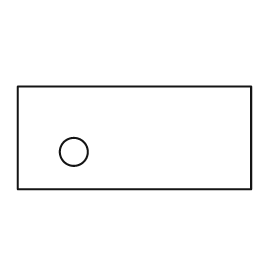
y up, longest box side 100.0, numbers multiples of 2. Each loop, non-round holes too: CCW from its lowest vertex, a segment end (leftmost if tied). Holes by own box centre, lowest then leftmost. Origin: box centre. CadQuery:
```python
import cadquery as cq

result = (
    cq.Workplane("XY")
    .moveTo(-50.0, -22.0)
    .lineTo(50.0, -22.0)
    .lineTo(50.0, 22.0)
    .lineTo(-50.0, 22.0)
    .close()
    .moveTo(-26.0, -6.0)
    .circle(6.0)
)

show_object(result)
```